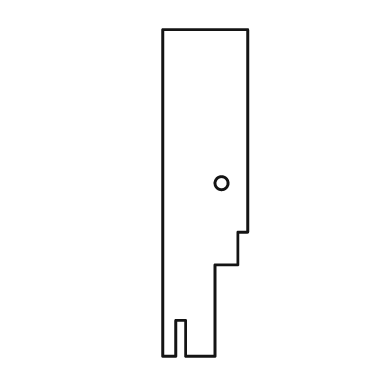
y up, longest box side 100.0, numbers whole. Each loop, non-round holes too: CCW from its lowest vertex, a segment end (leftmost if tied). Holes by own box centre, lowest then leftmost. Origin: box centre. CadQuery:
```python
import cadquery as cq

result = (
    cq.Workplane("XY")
    .moveTo(-13.0, -50.0)
    .lineTo(-9.0, -50.0)
    .lineTo(-9.0, -39.0)
    .lineTo(-6.0, -39.0)
    .lineTo(-6.0, -50.0)
    .lineTo(3.0, -50.0)
    .lineTo(3.0, -22.0)
    .lineTo(10.0, -22.0)
    .lineTo(10.0, -12.0)
    .lineTo(13.0, -12.0)
    .lineTo(13.0, 50.0)
    .lineTo(-13.0, 50.0)
    .close()
    .moveTo(5.0, 3.0)
    .circle(2.0)
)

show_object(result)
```